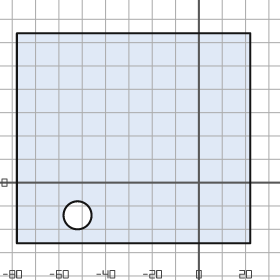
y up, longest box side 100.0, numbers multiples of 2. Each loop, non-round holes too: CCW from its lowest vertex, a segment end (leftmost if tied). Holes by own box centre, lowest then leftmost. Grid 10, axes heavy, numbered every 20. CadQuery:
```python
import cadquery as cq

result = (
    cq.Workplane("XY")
    .moveTo(-78.0, -26.0)
    .lineTo(22.0, -26.0)
    .lineTo(22.0, 64.0)
    .lineTo(-78.0, 64.0)
    .close()
    .moveTo(-52.0, -14.0)
    .circle(6.0)
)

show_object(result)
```